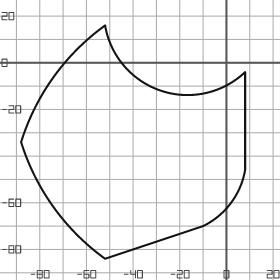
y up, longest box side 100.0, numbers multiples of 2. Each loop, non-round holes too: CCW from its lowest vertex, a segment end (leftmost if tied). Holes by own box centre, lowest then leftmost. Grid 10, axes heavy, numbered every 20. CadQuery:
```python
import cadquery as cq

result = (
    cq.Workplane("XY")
    .moveTo(-52.0, -84.0)
    .lineTo(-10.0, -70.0)
    .threePointArc((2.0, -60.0), (8.0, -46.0))
    .lineTo(8.0, -4.0)
    .threePointArc((-28.0, -12.0), (-52.0, 16.0))
    .threePointArc((-74.0, -6.0), (-88.0, -34.0))
    .threePointArc((-74.0, -62.0), (-52.0, -84.0))
    .close()
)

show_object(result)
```